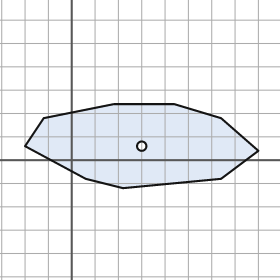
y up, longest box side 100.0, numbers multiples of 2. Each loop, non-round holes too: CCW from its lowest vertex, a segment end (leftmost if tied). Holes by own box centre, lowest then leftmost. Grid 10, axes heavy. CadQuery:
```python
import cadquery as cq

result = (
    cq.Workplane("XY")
    .moveTo(22.0, -12.0)
    .lineTo(64.0, -8.0)
    .lineTo(80.0, 4.0)
    .lineTo(64.0, 18.0)
    .lineTo(44.0, 24.0)
    .lineTo(18.0, 24.0)
    .lineTo(-12.0, 18.0)
    .lineTo(-20.0, 6.0)
    .lineTo(6.0, -8.0)
    .close()
    .moveTo(30.0, 6.0)
    .circle(2.0)
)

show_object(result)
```